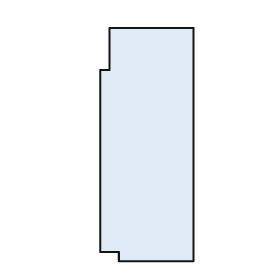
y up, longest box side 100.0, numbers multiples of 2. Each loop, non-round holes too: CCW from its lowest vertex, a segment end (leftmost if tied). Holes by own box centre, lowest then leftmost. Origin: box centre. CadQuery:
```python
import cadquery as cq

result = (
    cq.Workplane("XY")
    .moveTo(-12.0, -50.0)
    .lineTo(20.0, -50.0)
    .lineTo(20.0, 50.0)
    .lineTo(-16.0, 50.0)
    .lineTo(-16.0, 32.0)
    .lineTo(-20.0, 32.0)
    .lineTo(-20.0, -46.0)
    .lineTo(-12.0, -46.0)
    .close()
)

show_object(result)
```